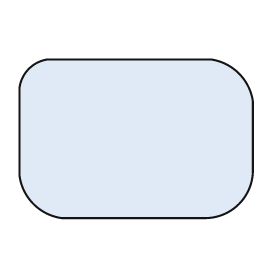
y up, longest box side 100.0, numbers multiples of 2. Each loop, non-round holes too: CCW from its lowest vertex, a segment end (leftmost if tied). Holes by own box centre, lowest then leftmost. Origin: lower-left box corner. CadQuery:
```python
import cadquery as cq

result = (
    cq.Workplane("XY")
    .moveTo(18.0, 0.0)
    .lineTo(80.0, 0.0)
    .threePointArc((94.0, 6.0), (100.0, 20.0))
    .lineTo(100.0, 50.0)
    .threePointArc((94.0, 62.0), (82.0, 68.0))
    .lineTo(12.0, 68.0)
    .threePointArc((4.0, 64.0), (0.0, 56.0))
    .lineTo(0.0, 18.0)
    .threePointArc((6.0, 6.0), (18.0, 0.0))
    .close()
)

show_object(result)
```